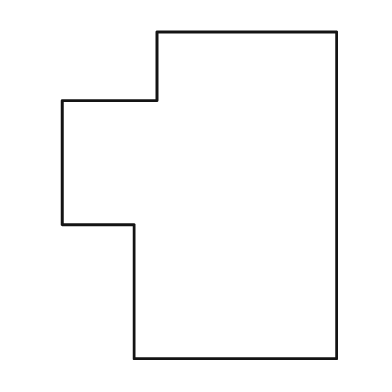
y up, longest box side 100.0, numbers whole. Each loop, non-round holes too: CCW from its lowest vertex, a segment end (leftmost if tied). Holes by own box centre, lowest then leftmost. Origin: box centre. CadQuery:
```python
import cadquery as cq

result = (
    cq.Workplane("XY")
    .moveTo(-20.0, -50.0)
    .lineTo(42.0, -50.0)
    .lineTo(42.0, 50.0)
    .lineTo(-13.0, 50.0)
    .lineTo(-13.0, 29.0)
    .lineTo(-42.0, 29.0)
    .lineTo(-42.0, -9.0)
    .lineTo(-20.0, -9.0)
    .close()
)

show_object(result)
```